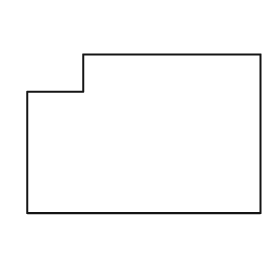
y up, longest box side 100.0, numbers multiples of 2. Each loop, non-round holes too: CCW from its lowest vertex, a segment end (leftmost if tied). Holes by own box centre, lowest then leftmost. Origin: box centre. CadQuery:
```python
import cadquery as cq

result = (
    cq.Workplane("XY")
    .moveTo(-50.0, -34.0)
    .lineTo(50.0, -34.0)
    .lineTo(50.0, 34.0)
    .lineTo(-26.0, 34.0)
    .lineTo(-26.0, 18.0)
    .lineTo(-50.0, 18.0)
    .close()
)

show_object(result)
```